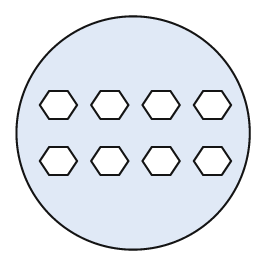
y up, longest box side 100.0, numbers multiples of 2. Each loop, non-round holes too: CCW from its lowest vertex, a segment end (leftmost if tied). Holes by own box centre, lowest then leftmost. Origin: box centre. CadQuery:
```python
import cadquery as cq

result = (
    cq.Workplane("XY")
    .moveTo(0.0, 0.0)
    .circle(50.0)
    .moveTo(-36.0, -18.0)
    .lineTo(-28.0, -18.0)
    .lineTo(-24.0, -12.0)
    .lineTo(-28.0, -6.0)
    .lineTo(-36.0, -6.0)
    .lineTo(-40.0, -12.0)
    .close()
    .moveTo(-14.0, -18.0)
    .lineTo(-6.0, -18.0)
    .lineTo(-2.0, -12.0)
    .lineTo(-6.0, -6.0)
    .lineTo(-14.0, -6.0)
    .lineTo(-18.0, -12.0)
    .close()
    .moveTo(8.0, -18.0)
    .lineTo(16.0, -18.0)
    .lineTo(20.0, -12.0)
    .lineTo(16.0, -6.0)
    .lineTo(8.0, -6.0)
    .lineTo(4.0, -12.0)
    .close()
    .moveTo(30.0, -18.0)
    .lineTo(38.0, -18.0)
    .lineTo(42.0, -12.0)
    .lineTo(38.0, -6.0)
    .lineTo(30.0, -6.0)
    .lineTo(26.0, -12.0)
    .close()
    .moveTo(-36.0, 6.0)
    .lineTo(-28.0, 6.0)
    .lineTo(-24.0, 12.0)
    .lineTo(-28.0, 18.0)
    .lineTo(-36.0, 18.0)
    .lineTo(-40.0, 12.0)
    .close()
    .moveTo(-14.0, 6.0)
    .lineTo(-6.0, 6.0)
    .lineTo(-2.0, 12.0)
    .lineTo(-6.0, 18.0)
    .lineTo(-14.0, 18.0)
    .lineTo(-18.0, 12.0)
    .close()
    .moveTo(8.0, 6.0)
    .lineTo(16.0, 6.0)
    .lineTo(20.0, 12.0)
    .lineTo(16.0, 18.0)
    .lineTo(8.0, 18.0)
    .lineTo(4.0, 12.0)
    .close()
    .moveTo(30.0, 6.0)
    .lineTo(38.0, 6.0)
    .lineTo(42.0, 12.0)
    .lineTo(38.0, 18.0)
    .lineTo(30.0, 18.0)
    .lineTo(26.0, 12.0)
    .close()
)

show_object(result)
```